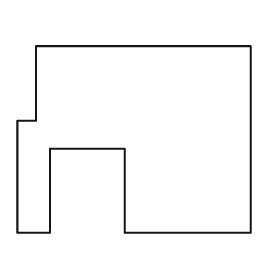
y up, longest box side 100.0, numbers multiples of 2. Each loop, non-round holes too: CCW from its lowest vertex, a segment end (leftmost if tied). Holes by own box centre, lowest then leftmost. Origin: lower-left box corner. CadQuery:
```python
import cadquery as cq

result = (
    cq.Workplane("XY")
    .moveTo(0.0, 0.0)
    .lineTo(14.0, 0.0)
    .lineTo(14.0, 36.0)
    .lineTo(46.0, 36.0)
    .lineTo(46.0, 0.0)
    .lineTo(100.0, 0.0)
    .lineTo(100.0, 80.0)
    .lineTo(8.0, 80.0)
    .lineTo(8.0, 48.0)
    .lineTo(0.0, 48.0)
    .close()
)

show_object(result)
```